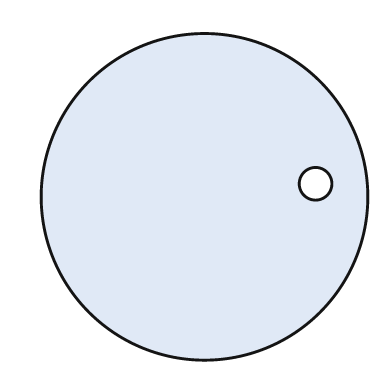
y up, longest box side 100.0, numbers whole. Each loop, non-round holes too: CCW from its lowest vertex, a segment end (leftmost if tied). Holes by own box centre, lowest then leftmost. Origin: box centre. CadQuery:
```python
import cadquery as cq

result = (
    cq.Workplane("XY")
    .moveTo(0.0, 0.0)
    .circle(50.0)
    .moveTo(34.0, 4.0)
    .circle(5.0)
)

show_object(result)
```